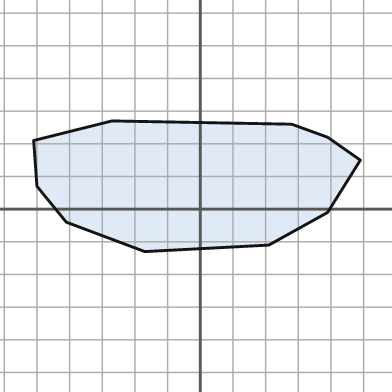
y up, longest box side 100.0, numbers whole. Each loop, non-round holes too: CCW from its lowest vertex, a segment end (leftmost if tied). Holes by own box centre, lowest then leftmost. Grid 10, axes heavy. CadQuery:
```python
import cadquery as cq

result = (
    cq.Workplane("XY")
    .moveTo(-17.0, -13.0)
    .lineTo(21.0, -11.0)
    .lineTo(39.0, -1.0)
    .lineTo(49.0, 15.0)
    .lineTo(39.0, 22.0)
    .lineTo(28.0, 26.0)
    .lineTo(-27.0, 27.0)
    .lineTo(-51.0, 21.0)
    .lineTo(-50.0, 7.0)
    .lineTo(-41.0, -4.0)
    .close()
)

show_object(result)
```